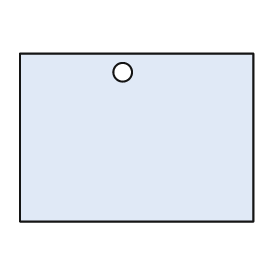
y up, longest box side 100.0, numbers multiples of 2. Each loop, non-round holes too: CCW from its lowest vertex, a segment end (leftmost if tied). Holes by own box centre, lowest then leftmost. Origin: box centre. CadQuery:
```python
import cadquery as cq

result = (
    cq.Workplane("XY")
    .moveTo(-50.0, -36.0)
    .lineTo(50.0, -36.0)
    .lineTo(50.0, 36.0)
    .lineTo(-50.0, 36.0)
    .close()
    .moveTo(-6.0, 28.0)
    .circle(4.0)
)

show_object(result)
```